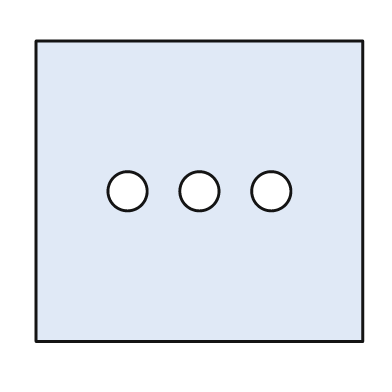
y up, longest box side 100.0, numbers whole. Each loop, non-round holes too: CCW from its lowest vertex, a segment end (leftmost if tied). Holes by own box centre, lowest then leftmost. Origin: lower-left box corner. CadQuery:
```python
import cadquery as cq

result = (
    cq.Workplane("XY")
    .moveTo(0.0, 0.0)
    .lineTo(100.0, 0.0)
    .lineTo(100.0, 92.0)
    .lineTo(0.0, 92.0)
    .close()
    .moveTo(28.0, 46.0)
    .circle(6.0)
    .moveTo(50.0, 46.0)
    .circle(6.0)
    .moveTo(72.0, 46.0)
    .circle(6.0)
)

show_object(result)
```